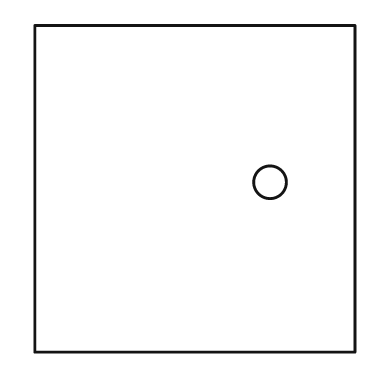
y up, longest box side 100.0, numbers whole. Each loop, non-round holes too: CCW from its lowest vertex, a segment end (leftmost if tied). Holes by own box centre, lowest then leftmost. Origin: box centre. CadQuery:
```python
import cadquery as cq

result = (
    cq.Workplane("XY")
    .moveTo(-49.0, -50.0)
    .lineTo(49.0, -50.0)
    .lineTo(49.0, 50.0)
    .lineTo(-49.0, 50.0)
    .close()
    .moveTo(23.0, 2.0)
    .circle(5.0)
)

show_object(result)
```